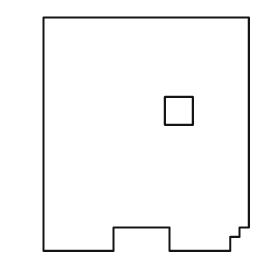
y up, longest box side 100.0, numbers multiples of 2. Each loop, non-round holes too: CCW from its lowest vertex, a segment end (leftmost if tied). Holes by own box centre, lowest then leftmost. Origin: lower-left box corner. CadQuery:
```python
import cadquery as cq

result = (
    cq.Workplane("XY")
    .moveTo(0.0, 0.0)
    .lineTo(30.0, 0.0)
    .lineTo(30.0, 10.0)
    .lineTo(54.0, 10.0)
    .lineTo(54.0, 0.0)
    .lineTo(80.0, 0.0)
    .lineTo(80.0, 6.0)
    .lineTo(84.0, 6.0)
    .lineTo(84.0, 10.0)
    .lineTo(88.0, 10.0)
    .lineTo(88.0, 100.0)
    .lineTo(0.0, 100.0)
    .close()
    .moveTo(52.0, 54.0)
    .lineTo(64.0, 54.0)
    .lineTo(64.0, 66.0)
    .lineTo(52.0, 66.0)
    .close()
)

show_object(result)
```